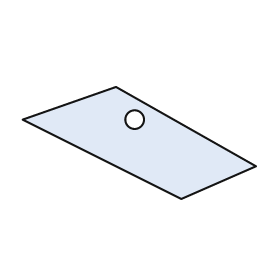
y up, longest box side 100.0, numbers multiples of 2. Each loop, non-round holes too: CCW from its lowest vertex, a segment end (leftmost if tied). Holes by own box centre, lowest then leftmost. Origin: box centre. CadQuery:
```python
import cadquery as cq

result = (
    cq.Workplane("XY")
    .moveTo(18.0, -24.0)
    .lineTo(50.0, -10.0)
    .lineTo(-10.0, 24.0)
    .lineTo(-50.0, 10.0)
    .close()
    .moveTo(-2.0, 10.0)
    .circle(4.0)
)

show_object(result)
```